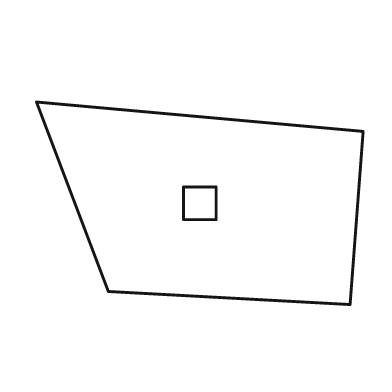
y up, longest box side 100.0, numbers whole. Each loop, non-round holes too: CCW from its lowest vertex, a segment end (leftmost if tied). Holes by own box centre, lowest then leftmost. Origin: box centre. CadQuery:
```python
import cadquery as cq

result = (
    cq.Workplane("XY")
    .moveTo(46.0, -31.0)
    .lineTo(50.0, 22.0)
    .lineTo(-50.0, 31.0)
    .lineTo(-28.0, -27.0)
    .close()
    .moveTo(-5.0, -5.0)
    .lineTo(5.0, -5.0)
    .lineTo(5.0, 5.0)
    .lineTo(-5.0, 5.0)
    .close()
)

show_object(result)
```